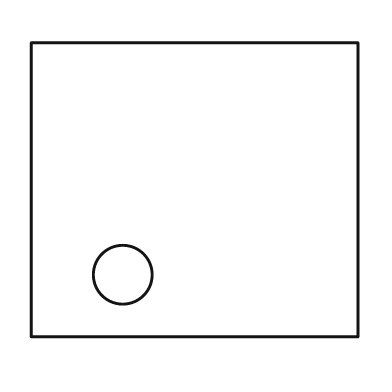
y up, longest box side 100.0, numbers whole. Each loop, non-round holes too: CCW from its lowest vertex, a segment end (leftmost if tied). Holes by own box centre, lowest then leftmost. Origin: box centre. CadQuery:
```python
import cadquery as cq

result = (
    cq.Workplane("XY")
    .moveTo(-50.0, -45.0)
    .lineTo(50.0, -45.0)
    .lineTo(50.0, 45.0)
    .lineTo(-50.0, 45.0)
    .close()
    .moveTo(-22.0, -26.0)
    .circle(9.0)
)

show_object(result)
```